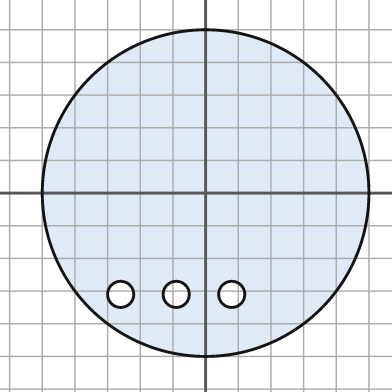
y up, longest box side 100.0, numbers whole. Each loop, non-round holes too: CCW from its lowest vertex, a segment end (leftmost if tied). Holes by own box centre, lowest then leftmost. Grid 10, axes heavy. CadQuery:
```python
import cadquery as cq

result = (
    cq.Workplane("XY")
    .moveTo(0.0, 0.0)
    .circle(50.0)
    .moveTo(-26.0, -31.0)
    .circle(4.0)
    .moveTo(-9.0, -31.0)
    .circle(4.0)
    .moveTo(8.0, -31.0)
    .circle(4.0)
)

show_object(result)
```